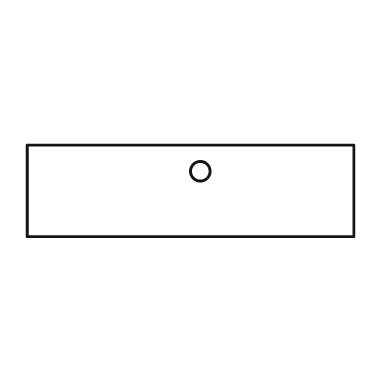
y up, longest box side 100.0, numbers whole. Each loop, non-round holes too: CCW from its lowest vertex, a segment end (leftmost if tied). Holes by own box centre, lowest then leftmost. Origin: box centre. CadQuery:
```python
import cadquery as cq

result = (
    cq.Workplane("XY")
    .moveTo(-50.0, -14.0)
    .lineTo(50.0, -14.0)
    .lineTo(50.0, 14.0)
    .lineTo(-50.0, 14.0)
    .close()
    .moveTo(3.0, 6.0)
    .circle(3.0)
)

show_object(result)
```